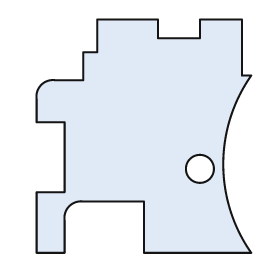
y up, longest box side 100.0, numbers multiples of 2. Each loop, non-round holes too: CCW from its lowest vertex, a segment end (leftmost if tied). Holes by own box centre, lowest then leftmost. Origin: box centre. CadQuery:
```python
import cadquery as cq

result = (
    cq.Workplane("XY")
    .moveTo(-46.0, -50.0)
    .lineTo(-34.0, -50.0)
    .lineTo(-34.0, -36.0)
    .threePointArc((-32.0, -30.0), (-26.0, -28.0))
    .lineTo(0.0, -28.0)
    .lineTo(0.0, -50.0)
    .lineTo(46.0, -50.0)
    .threePointArc((34.0, -12.0), (46.0, 26.0))
    .lineTo(42.0, 26.0)
    .lineTo(42.0, 50.0)
    .lineTo(24.0, 50.0)
    .lineTo(24.0, 42.0)
    .lineTo(6.0, 42.0)
    .lineTo(6.0, 50.0)
    .lineTo(-20.0, 50.0)
    .lineTo(-20.0, 36.0)
    .lineTo(-26.0, 36.0)
    .lineTo(-26.0, 24.0)
    .lineTo(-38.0, 24.0)
    .threePointArc((-44.0, 22.0), (-46.0, 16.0))
    .lineTo(-46.0, 6.0)
    .lineTo(-34.0, 6.0)
    .lineTo(-34.0, -24.0)
    .lineTo(-46.0, -24.0)
    .close()
    .moveTo(24.0, -14.0)
    .circle(6.0)
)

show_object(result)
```